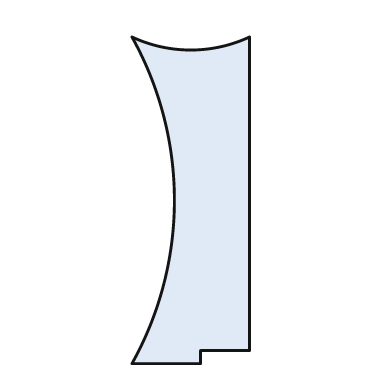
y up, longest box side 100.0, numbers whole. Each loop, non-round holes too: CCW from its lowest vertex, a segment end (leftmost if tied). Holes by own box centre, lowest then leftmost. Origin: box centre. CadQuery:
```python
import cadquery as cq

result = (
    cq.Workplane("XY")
    .moveTo(-18.0, -50.0)
    .lineTo(3.0, -50.0)
    .lineTo(3.0, -46.0)
    .lineTo(18.0, -46.0)
    .lineTo(18.0, 50.0)
    .threePointArc((0.0, 46.0), (-18.0, 50.0))
    .threePointArc((-5.0, 0.0), (-18.0, -50.0))
    .close()
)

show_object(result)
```